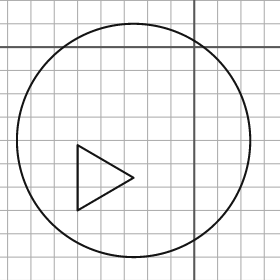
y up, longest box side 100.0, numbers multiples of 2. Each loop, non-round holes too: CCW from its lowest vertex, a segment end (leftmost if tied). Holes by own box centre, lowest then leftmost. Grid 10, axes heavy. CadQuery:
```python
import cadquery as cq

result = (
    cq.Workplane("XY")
    .moveTo(-26.0, -40.0)
    .circle(50.0)
    .moveTo(-50.0, -70.0)
    .lineTo(-26.0, -56.0)
    .lineTo(-50.0, -42.0)
    .close()
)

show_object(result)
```